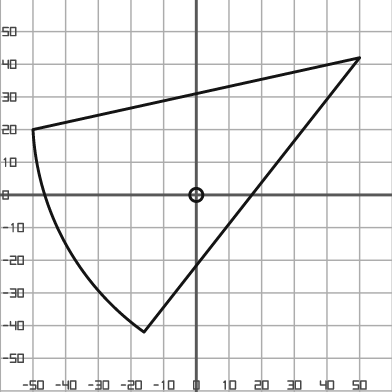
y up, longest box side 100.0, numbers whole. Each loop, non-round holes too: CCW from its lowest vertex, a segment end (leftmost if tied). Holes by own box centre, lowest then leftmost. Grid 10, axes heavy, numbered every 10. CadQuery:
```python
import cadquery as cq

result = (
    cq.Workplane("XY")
    .moveTo(-16.0, -42.0)
    .lineTo(50.0, 42.0)
    .lineTo(-50.0, 20.0)
    .threePointArc((-40.0, -15.0), (-16.0, -42.0))
    .close()
    .moveTo(0.0, 0.0)
    .circle(2.0)
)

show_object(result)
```